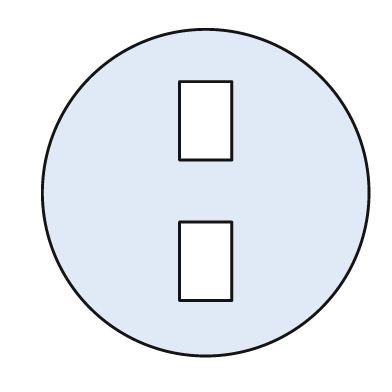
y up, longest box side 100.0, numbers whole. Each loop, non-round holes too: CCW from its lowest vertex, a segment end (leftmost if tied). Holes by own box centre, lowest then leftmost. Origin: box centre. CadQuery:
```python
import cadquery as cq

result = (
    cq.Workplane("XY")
    .moveTo(0.0, 0.0)
    .circle(50.0)
    .moveTo(-8.0, -33.0)
    .lineTo(8.0, -33.0)
    .lineTo(8.0, -9.0)
    .lineTo(-8.0, -9.0)
    .close()
    .moveTo(-8.0, 10.0)
    .lineTo(8.0, 10.0)
    .lineTo(8.0, 34.0)
    .lineTo(-8.0, 34.0)
    .close()
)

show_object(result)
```